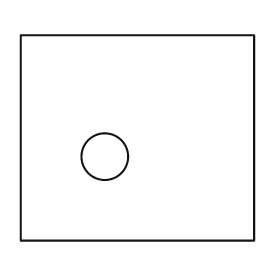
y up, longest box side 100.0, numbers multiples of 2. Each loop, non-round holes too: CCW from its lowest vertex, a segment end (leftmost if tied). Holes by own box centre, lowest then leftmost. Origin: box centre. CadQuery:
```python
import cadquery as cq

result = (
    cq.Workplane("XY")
    .moveTo(-50.0, -44.0)
    .lineTo(50.0, -44.0)
    .lineTo(50.0, 44.0)
    .lineTo(-50.0, 44.0)
    .close()
    .moveTo(-14.0, -8.0)
    .circle(10.0)
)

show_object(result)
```